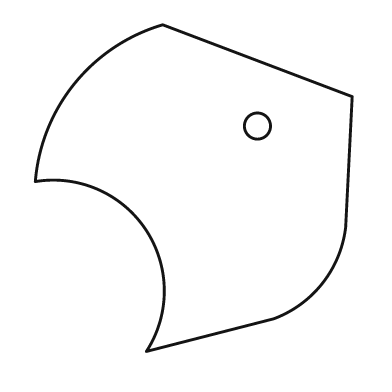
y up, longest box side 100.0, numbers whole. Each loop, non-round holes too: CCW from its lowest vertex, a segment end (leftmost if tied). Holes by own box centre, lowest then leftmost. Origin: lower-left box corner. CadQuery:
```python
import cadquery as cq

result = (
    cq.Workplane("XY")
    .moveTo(34.0, 0.0)
    .lineTo(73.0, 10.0)
    .threePointArc((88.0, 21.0), (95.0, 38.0))
    .lineTo(97.0, 78.0)
    .lineTo(39.0, 100.0)
    .threePointArc((12.0, 82.0), (0.0, 52.0))
    .threePointArc((34.0, 37.0), (34.0, 0.0))
    .close()
    .moveTo(68.0, 69.0)
    .circle(4.0)
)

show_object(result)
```